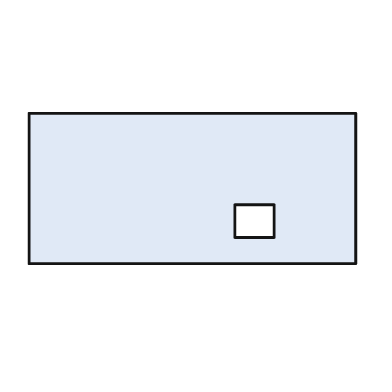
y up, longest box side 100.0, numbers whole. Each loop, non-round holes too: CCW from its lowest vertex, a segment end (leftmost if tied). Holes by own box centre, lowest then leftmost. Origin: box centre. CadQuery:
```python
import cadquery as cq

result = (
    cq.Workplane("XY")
    .moveTo(-50.0, -23.0)
    .lineTo(50.0, -23.0)
    .lineTo(50.0, 23.0)
    .lineTo(-50.0, 23.0)
    .close()
    .moveTo(13.0, -15.0)
    .lineTo(25.0, -15.0)
    .lineTo(25.0, -5.0)
    .lineTo(13.0, -5.0)
    .close()
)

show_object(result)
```